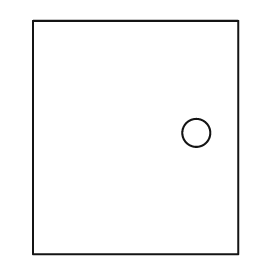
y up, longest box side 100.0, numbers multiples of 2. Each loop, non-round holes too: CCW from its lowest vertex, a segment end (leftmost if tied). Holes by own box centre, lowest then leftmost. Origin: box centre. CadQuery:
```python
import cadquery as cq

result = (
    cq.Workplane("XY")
    .moveTo(-44.0, -50.0)
    .lineTo(44.0, -50.0)
    .lineTo(44.0, 50.0)
    .lineTo(-44.0, 50.0)
    .close()
    .moveTo(26.0, 2.0)
    .circle(6.0)
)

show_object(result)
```